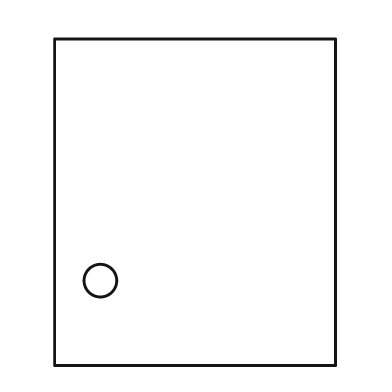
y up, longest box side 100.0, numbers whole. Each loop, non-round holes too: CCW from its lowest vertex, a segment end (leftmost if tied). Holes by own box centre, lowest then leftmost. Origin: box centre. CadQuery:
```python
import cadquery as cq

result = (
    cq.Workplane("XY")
    .moveTo(-43.0, -50.0)
    .lineTo(43.0, -50.0)
    .lineTo(43.0, 50.0)
    .lineTo(-43.0, 50.0)
    .close()
    .moveTo(-29.0, -24.0)
    .circle(5.0)
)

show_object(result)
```